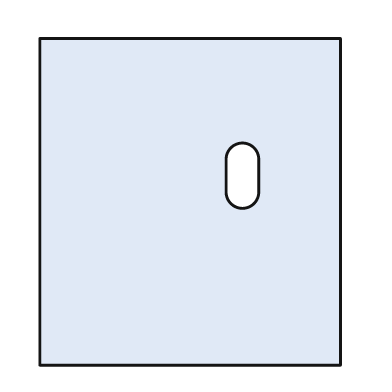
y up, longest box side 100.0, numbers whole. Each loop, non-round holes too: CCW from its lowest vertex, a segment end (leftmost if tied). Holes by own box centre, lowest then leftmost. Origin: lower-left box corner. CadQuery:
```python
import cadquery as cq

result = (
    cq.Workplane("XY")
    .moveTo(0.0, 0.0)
    .lineTo(92.0, 0.0)
    .lineTo(92.0, 100.0)
    .lineTo(0.0, 100.0)
    .close()
    .moveTo(57.0, 53.0)
    .threePointArc((62.0, 48.0), (67.0, 53.0))
    .lineTo(67.0, 63.0)
    .threePointArc((62.0, 68.0), (57.0, 63.0))
    .close()
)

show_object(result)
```